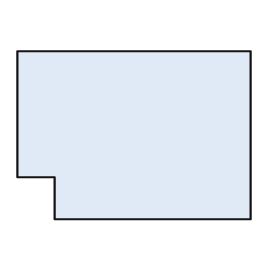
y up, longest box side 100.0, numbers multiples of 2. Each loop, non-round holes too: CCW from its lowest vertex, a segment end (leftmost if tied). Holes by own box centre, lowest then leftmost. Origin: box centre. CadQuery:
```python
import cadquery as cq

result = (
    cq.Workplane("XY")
    .moveTo(-34.0, -36.0)
    .lineTo(50.0, -36.0)
    .lineTo(50.0, 36.0)
    .lineTo(-50.0, 36.0)
    .lineTo(-50.0, -18.0)
    .lineTo(-34.0, -18.0)
    .close()
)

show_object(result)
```